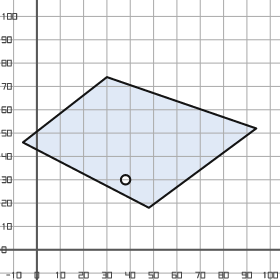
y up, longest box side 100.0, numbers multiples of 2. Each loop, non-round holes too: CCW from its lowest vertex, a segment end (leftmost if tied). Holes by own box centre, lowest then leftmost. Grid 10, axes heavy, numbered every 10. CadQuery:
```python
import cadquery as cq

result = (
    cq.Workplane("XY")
    .moveTo(48.0, 18.0)
    .lineTo(94.0, 52.0)
    .lineTo(30.0, 74.0)
    .lineTo(-6.0, 46.0)
    .close()
    .moveTo(38.0, 30.0)
    .circle(2.0)
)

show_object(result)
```